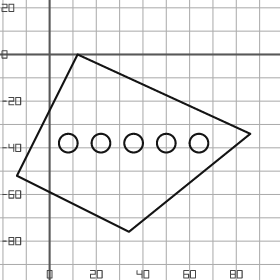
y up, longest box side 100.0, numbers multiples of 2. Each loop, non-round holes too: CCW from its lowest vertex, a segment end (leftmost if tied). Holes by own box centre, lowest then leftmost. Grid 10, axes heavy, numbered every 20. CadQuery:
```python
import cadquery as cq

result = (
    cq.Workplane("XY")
    .moveTo(34.0, -76.0)
    .lineTo(86.0, -34.0)
    .lineTo(12.0, 0.0)
    .lineTo(-14.0, -52.0)
    .close()
    .moveTo(8.0, -38.0)
    .circle(4.0)
    .moveTo(22.0, -38.0)
    .circle(4.0)
    .moveTo(36.0, -38.0)
    .circle(4.0)
    .moveTo(50.0, -38.0)
    .circle(4.0)
    .moveTo(64.0, -38.0)
    .circle(4.0)
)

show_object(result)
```